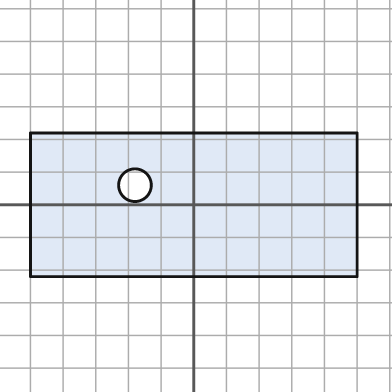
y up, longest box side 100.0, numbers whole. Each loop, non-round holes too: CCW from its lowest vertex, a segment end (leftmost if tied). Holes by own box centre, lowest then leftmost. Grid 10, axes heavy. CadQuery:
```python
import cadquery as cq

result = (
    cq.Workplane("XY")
    .moveTo(-50.0, -22.0)
    .lineTo(50.0, -22.0)
    .lineTo(50.0, 22.0)
    .lineTo(-50.0, 22.0)
    .close()
    .moveTo(-18.0, 6.0)
    .circle(5.0)
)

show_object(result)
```